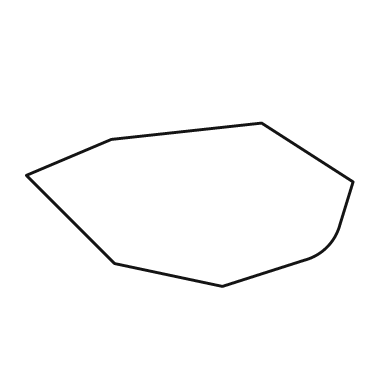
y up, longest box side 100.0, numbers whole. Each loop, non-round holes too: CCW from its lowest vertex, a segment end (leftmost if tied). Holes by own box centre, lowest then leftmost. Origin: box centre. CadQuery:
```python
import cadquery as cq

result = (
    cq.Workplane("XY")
    .moveTo(10.0, -25.0)
    .lineTo(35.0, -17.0)
    .threePointArc((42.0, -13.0), (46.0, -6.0))
    .lineTo(50.0, 7.0)
    .lineTo(22.0, 25.0)
    .lineTo(-24.0, 20.0)
    .lineTo(-50.0, 9.0)
    .lineTo(-23.0, -18.0)
    .close()
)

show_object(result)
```